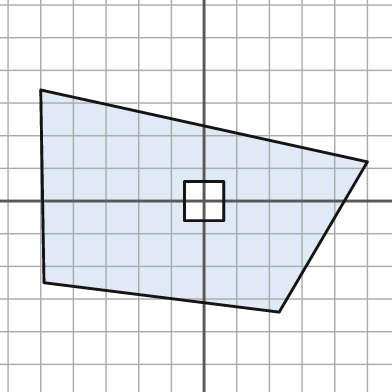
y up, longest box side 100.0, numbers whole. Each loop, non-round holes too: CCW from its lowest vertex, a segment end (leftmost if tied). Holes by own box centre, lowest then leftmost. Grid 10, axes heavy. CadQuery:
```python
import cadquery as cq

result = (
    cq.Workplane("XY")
    .moveTo(23.0, -34.0)
    .lineTo(50.0, 12.0)
    .lineTo(-50.0, 34.0)
    .lineTo(-49.0, -25.0)
    .close()
    .moveTo(-6.0, -6.0)
    .lineTo(6.0, -6.0)
    .lineTo(6.0, 6.0)
    .lineTo(-6.0, 6.0)
    .close()
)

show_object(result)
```